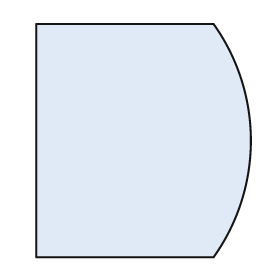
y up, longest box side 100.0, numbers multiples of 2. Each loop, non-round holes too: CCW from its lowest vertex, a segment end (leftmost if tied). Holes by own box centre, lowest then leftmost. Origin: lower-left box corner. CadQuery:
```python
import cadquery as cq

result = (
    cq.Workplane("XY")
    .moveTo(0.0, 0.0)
    .lineTo(76.0, 0.0)
    .threePointArc((92.0, 50.0), (76.0, 100.0))
    .lineTo(0.0, 100.0)
    .close()
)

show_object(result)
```